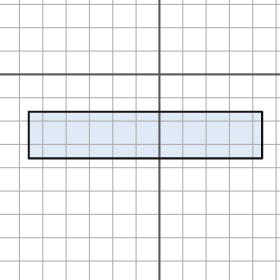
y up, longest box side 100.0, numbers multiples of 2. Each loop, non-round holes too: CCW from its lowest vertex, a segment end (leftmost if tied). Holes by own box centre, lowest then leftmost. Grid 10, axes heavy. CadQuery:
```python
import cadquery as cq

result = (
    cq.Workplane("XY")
    .moveTo(-56.0, -36.0)
    .lineTo(44.0, -36.0)
    .lineTo(44.0, -16.0)
    .lineTo(-56.0, -16.0)
    .close()
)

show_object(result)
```